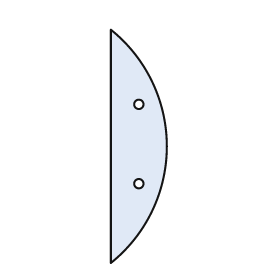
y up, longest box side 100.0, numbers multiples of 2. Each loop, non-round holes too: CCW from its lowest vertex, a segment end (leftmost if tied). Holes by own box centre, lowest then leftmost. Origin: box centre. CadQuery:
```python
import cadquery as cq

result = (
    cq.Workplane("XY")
    .moveTo(-12.0, -50.0)
    .threePointArc((12.0, 0.0), (-12.0, 50.0))
    .close()
    .moveTo(0.0, -16.0)
    .circle(2.0)
    .moveTo(0.0, 18.0)
    .circle(2.0)
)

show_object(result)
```